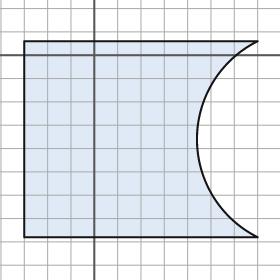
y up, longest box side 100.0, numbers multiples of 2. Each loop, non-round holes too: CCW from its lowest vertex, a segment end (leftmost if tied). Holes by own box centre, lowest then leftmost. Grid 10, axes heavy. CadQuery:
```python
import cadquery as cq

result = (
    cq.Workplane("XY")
    .moveTo(-30.0, -78.0)
    .lineTo(70.0, -78.0)
    .threePointArc((44.0, -36.0), (70.0, 6.0))
    .lineTo(-30.0, 6.0)
    .close()
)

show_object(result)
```